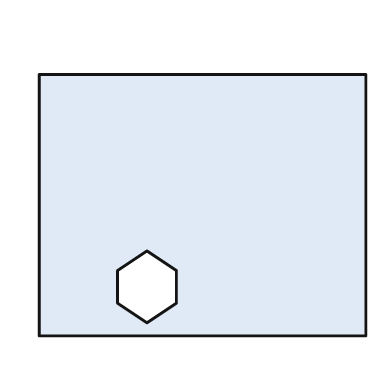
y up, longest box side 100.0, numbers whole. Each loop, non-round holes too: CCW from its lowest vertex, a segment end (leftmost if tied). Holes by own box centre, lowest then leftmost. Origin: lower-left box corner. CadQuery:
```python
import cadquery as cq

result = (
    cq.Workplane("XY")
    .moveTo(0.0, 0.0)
    .lineTo(100.0, 0.0)
    .lineTo(100.0, 80.0)
    .lineTo(0.0, 80.0)
    .close()
    .moveTo(33.0, 4.0)
    .lineTo(42.0, 10.0)
    .lineTo(42.0, 20.0)
    .lineTo(33.0, 26.0)
    .lineTo(24.0, 20.0)
    .lineTo(24.0, 10.0)
    .close()
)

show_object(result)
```